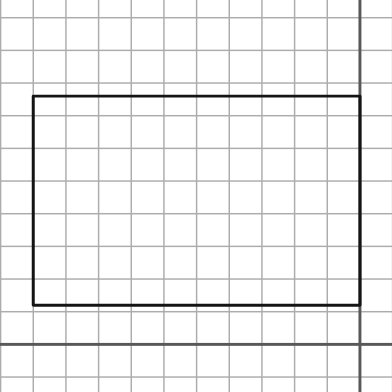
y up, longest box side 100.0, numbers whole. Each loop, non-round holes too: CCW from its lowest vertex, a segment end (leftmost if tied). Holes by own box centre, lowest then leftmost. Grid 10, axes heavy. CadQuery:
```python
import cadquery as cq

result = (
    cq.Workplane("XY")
    .moveTo(-100.0, 12.0)
    .lineTo(0.0, 12.0)
    .lineTo(0.0, 76.0)
    .lineTo(-100.0, 76.0)
    .close()
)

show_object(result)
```